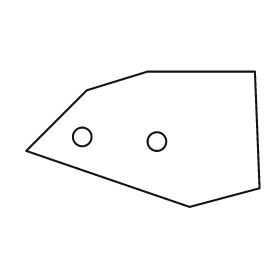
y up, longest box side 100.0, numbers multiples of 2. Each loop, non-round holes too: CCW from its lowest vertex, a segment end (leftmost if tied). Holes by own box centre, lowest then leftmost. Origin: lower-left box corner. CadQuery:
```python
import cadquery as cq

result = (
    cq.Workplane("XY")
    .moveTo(70.0, 0.0)
    .lineTo(100.0, 8.0)
    .lineTo(98.0, 58.0)
    .lineTo(52.0, 58.0)
    .lineTo(26.0, 50.0)
    .lineTo(0.0, 24.0)
    .close()
    .moveTo(56.0, 28.0)
    .circle(4.0)
    .moveTo(24.0, 30.0)
    .circle(4.0)
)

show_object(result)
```